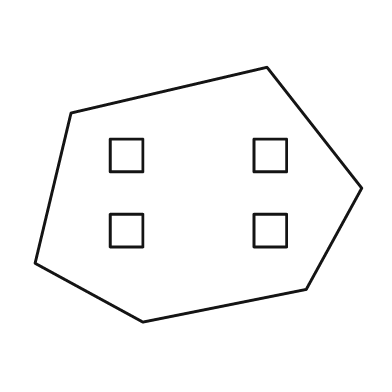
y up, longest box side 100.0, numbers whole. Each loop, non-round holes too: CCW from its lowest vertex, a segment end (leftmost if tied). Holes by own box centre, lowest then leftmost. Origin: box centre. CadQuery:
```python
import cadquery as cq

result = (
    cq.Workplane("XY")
    .moveTo(-17.0, -39.0)
    .lineTo(33.0, -29.0)
    .lineTo(50.0, 2.0)
    .lineTo(21.0, 39.0)
    .lineTo(-39.0, 25.0)
    .lineTo(-50.0, -21.0)
    .close()
    .moveTo(-27.0, -16.0)
    .lineTo(-17.0, -16.0)
    .lineTo(-17.0, -6.0)
    .lineTo(-27.0, -6.0)
    .close()
    .moveTo(17.0, -16.0)
    .lineTo(27.0, -16.0)
    .lineTo(27.0, -6.0)
    .lineTo(17.0, -6.0)
    .close()
    .moveTo(-27.0, 7.0)
    .lineTo(-17.0, 7.0)
    .lineTo(-17.0, 17.0)
    .lineTo(-27.0, 17.0)
    .close()
    .moveTo(17.0, 7.0)
    .lineTo(27.0, 7.0)
    .lineTo(27.0, 17.0)
    .lineTo(17.0, 17.0)
    .close()
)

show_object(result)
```